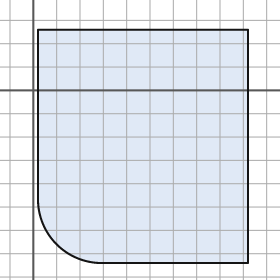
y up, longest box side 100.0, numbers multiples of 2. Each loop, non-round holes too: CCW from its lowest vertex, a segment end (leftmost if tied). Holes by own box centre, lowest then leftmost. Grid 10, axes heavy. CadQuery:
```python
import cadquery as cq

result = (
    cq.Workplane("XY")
    .moveTo(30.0, -74.0)
    .lineTo(92.0, -74.0)
    .lineTo(92.0, 26.0)
    .lineTo(2.0, 26.0)
    .lineTo(2.0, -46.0)
    .threePointArc((10.0, -66.0), (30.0, -74.0))
    .close()
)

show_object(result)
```